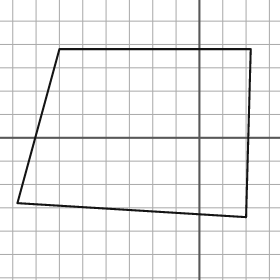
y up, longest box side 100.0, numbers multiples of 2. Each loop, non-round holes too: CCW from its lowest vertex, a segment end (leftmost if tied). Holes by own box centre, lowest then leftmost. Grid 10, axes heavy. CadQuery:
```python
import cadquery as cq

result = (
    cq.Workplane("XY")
    .moveTo(20.0, -34.0)
    .lineTo(22.0, 38.0)
    .lineTo(-60.0, 38.0)
    .lineTo(-78.0, -28.0)
    .close()
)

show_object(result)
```